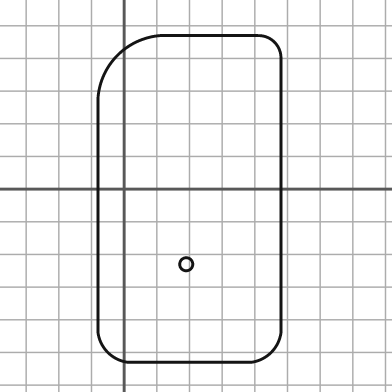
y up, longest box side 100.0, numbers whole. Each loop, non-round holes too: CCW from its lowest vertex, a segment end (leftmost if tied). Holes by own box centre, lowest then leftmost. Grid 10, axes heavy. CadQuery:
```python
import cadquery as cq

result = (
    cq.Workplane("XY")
    .moveTo(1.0, -53.0)
    .lineTo(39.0, -53.0)
    .threePointArc((45.0, -50.0), (48.0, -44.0))
    .lineTo(48.0, 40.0)
    .threePointArc((46.0, 45.0), (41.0, 47.0))
    .lineTo(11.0, 47.0)
    .threePointArc((-2.0, 41.0), (-8.0, 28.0))
    .lineTo(-8.0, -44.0)
    .threePointArc((-5.0, -50.0), (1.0, -53.0))
    .close()
    .moveTo(19.0, -23.0)
    .circle(2.0)
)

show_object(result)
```